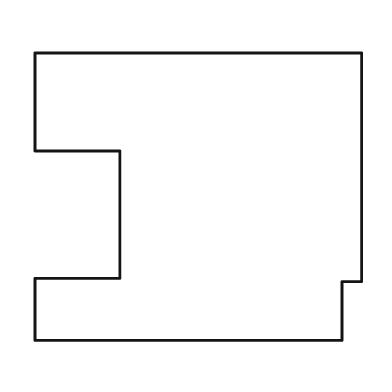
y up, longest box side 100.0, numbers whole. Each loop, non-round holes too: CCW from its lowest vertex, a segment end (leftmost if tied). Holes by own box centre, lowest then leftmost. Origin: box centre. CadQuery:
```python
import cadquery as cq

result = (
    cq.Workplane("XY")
    .moveTo(-50.0, -44.0)
    .lineTo(44.0, -44.0)
    .lineTo(44.0, -26.0)
    .lineTo(50.0, -26.0)
    .lineTo(50.0, 44.0)
    .lineTo(-50.0, 44.0)
    .lineTo(-50.0, 14.0)
    .lineTo(-24.0, 14.0)
    .lineTo(-24.0, -25.0)
    .lineTo(-50.0, -25.0)
    .close()
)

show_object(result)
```